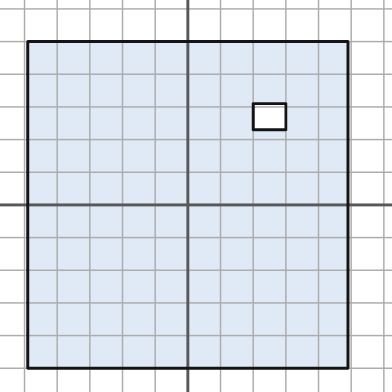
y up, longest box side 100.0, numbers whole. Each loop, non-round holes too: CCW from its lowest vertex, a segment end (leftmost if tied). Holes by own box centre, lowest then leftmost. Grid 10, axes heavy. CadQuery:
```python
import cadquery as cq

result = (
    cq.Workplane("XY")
    .moveTo(-49.0, -50.0)
    .lineTo(49.0, -50.0)
    .lineTo(49.0, 50.0)
    .lineTo(-49.0, 50.0)
    .close()
    .moveTo(20.0, 23.0)
    .lineTo(30.0, 23.0)
    .lineTo(30.0, 31.0)
    .lineTo(20.0, 31.0)
    .close()
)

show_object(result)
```